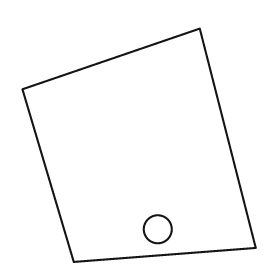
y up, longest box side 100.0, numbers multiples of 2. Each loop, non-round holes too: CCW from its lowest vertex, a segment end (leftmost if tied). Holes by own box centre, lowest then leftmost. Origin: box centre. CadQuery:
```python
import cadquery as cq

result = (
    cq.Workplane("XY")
    .moveTo(-28.0, -50.0)
    .lineTo(50.0, -44.0)
    .lineTo(26.0, 50.0)
    .lineTo(-50.0, 24.0)
    .close()
    .moveTo(8.0, -36.0)
    .circle(6.0)
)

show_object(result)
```